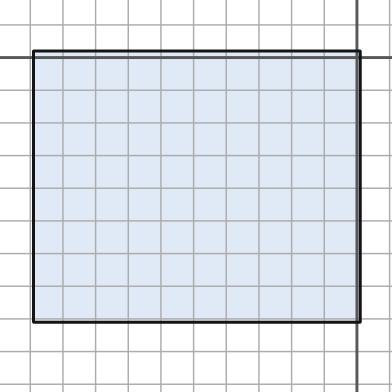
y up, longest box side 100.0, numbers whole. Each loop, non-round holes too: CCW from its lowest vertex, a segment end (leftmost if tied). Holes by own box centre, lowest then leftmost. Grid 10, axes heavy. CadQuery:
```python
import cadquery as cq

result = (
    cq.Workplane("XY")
    .moveTo(-99.0, -81.0)
    .lineTo(1.0, -81.0)
    .lineTo(1.0, 2.0)
    .lineTo(-99.0, 2.0)
    .close()
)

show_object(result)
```